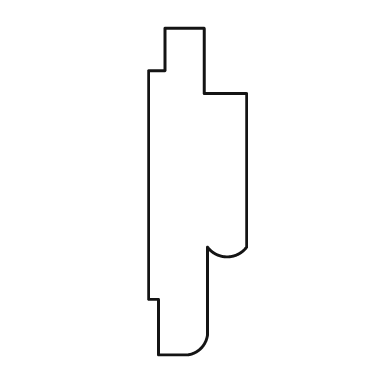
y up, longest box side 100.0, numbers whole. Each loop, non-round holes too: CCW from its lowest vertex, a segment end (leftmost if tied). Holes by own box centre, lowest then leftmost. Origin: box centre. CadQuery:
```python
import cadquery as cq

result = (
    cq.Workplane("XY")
    .moveTo(-12.0, -50.0)
    .lineTo(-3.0, -50.0)
    .threePointArc((1.0, -48.0), (3.0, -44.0))
    .lineTo(3.0, -17.0)
    .threePointArc((9.0, -20.0), (15.0, -17.0))
    .lineTo(15.0, 30.0)
    .lineTo(2.0, 30.0)
    .lineTo(2.0, 50.0)
    .lineTo(-10.0, 50.0)
    .lineTo(-10.0, 37.0)
    .lineTo(-15.0, 37.0)
    .lineTo(-15.0, -33.0)
    .lineTo(-12.0, -33.0)
    .close()
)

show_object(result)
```